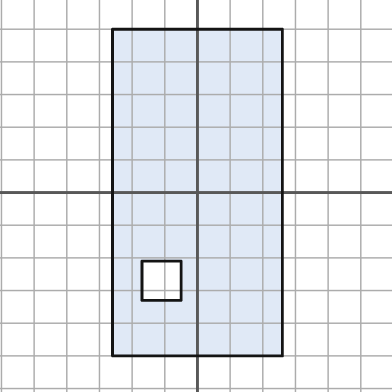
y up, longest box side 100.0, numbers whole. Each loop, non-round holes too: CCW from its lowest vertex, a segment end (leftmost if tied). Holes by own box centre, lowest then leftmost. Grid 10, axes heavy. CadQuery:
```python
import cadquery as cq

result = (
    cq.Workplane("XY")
    .moveTo(-26.0, -50.0)
    .lineTo(26.0, -50.0)
    .lineTo(26.0, 50.0)
    .lineTo(-26.0, 50.0)
    .close()
    .moveTo(-17.0, -33.0)
    .lineTo(-5.0, -33.0)
    .lineTo(-5.0, -21.0)
    .lineTo(-17.0, -21.0)
    .close()
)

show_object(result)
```